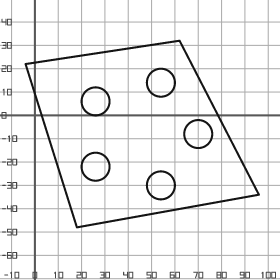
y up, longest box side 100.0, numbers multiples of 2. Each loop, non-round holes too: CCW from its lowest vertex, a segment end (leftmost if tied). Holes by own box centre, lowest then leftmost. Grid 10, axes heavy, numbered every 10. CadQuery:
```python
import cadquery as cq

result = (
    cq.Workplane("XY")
    .moveTo(18.0, -48.0)
    .lineTo(96.0, -34.0)
    .lineTo(62.0, 32.0)
    .lineTo(-4.0, 22.0)
    .close()
    .moveTo(54.0, -30.0)
    .circle(6.0)
    .moveTo(26.0, -22.0)
    .circle(6.0)
    .moveTo(70.0, -8.0)
    .circle(6.0)
    .moveTo(26.0, 6.0)
    .circle(6.0)
    .moveTo(54.0, 14.0)
    .circle(6.0)
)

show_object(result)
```